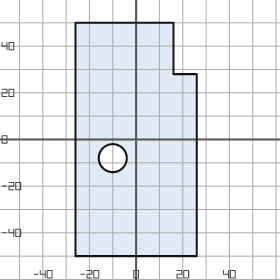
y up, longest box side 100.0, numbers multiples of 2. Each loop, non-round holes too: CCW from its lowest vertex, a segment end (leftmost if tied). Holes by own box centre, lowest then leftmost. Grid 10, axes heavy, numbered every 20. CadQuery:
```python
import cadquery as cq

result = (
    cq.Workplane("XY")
    .moveTo(-26.0, -50.0)
    .lineTo(26.0, -50.0)
    .lineTo(26.0, 28.0)
    .lineTo(16.0, 28.0)
    .lineTo(16.0, 50.0)
    .lineTo(-26.0, 50.0)
    .close()
    .moveTo(-10.0, -8.0)
    .circle(6.0)
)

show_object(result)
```